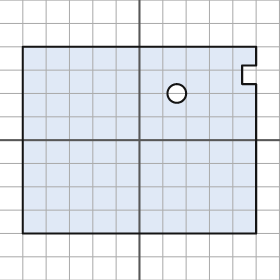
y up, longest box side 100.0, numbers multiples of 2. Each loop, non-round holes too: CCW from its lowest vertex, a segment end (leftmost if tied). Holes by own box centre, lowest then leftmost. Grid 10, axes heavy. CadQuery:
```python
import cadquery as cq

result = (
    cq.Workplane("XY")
    .moveTo(-50.0, -40.0)
    .lineTo(50.0, -40.0)
    .lineTo(50.0, 24.0)
    .lineTo(44.0, 24.0)
    .lineTo(44.0, 32.0)
    .lineTo(50.0, 32.0)
    .lineTo(50.0, 40.0)
    .lineTo(-50.0, 40.0)
    .close()
    .moveTo(16.0, 20.0)
    .circle(4.0)
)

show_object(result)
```